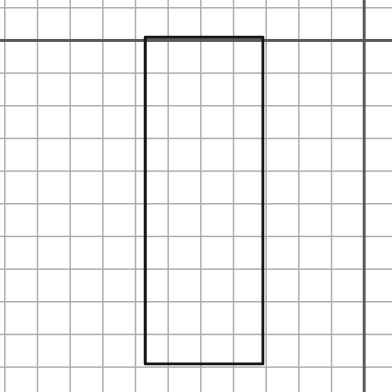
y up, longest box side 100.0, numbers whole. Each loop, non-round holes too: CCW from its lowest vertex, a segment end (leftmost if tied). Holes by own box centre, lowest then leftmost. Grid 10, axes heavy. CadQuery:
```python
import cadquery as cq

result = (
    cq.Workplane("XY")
    .moveTo(-67.0, -99.0)
    .lineTo(-31.0, -99.0)
    .lineTo(-31.0, 1.0)
    .lineTo(-67.0, 1.0)
    .close()
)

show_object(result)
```